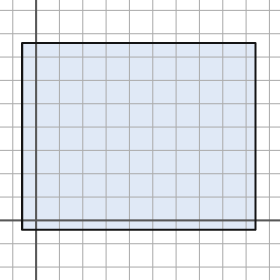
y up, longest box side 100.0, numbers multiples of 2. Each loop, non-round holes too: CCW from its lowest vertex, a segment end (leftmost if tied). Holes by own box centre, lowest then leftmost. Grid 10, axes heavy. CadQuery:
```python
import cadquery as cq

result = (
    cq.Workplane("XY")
    .moveTo(-6.0, -4.0)
    .lineTo(94.0, -4.0)
    .lineTo(94.0, 76.0)
    .lineTo(-6.0, 76.0)
    .close()
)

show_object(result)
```